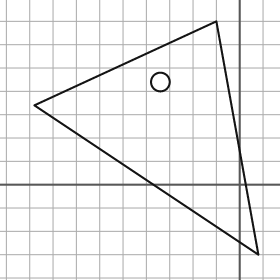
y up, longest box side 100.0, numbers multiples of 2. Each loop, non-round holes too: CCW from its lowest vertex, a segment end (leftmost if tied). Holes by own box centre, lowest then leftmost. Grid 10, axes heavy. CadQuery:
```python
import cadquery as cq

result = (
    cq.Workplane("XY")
    .moveTo(8.0, -30.0)
    .lineTo(-10.0, 70.0)
    .lineTo(-88.0, 34.0)
    .close()
    .moveTo(-34.0, 44.0)
    .circle(4.0)
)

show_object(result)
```